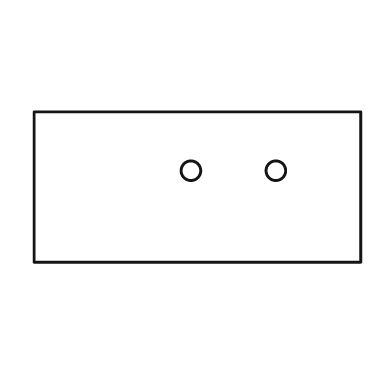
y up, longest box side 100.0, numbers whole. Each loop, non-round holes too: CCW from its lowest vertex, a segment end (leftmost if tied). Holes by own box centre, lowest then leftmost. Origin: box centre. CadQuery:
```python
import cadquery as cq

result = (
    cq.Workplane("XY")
    .moveTo(-50.0, -23.0)
    .lineTo(50.0, -23.0)
    .lineTo(50.0, 23.0)
    .lineTo(-50.0, 23.0)
    .close()
    .moveTo(-2.0, 5.0)
    .circle(3.0)
    .moveTo(24.0, 5.0)
    .circle(3.0)
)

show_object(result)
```